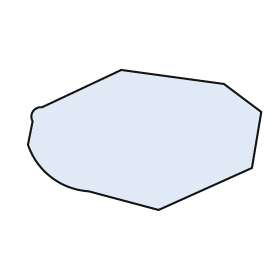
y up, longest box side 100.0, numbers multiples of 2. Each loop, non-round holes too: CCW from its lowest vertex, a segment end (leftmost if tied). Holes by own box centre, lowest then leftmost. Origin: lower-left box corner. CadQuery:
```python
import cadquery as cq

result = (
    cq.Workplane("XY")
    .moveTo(56.0, 0.0)
    .lineTo(96.0, 18.0)
    .lineTo(100.0, 42.0)
    .lineTo(84.0, 54.0)
    .lineTo(40.0, 60.0)
    .lineTo(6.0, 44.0)
    .threePointArc((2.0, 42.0), (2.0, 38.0))
    .lineTo(0.0, 28.0)
    .threePointArc((10.0, 14.0), (26.0, 8.0))
    .close()
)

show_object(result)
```